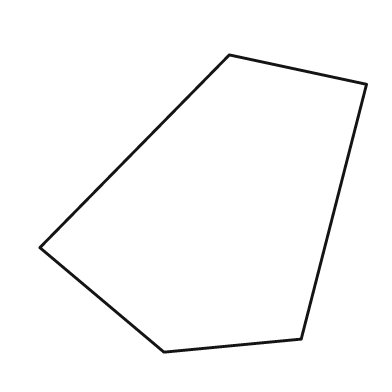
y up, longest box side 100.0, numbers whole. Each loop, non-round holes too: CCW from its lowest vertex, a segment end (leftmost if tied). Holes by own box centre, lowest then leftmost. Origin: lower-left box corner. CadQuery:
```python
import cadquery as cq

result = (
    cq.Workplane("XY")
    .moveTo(38.0, 0.0)
    .lineTo(80.0, 4.0)
    .lineTo(100.0, 82.0)
    .lineTo(58.0, 91.0)
    .lineTo(0.0, 32.0)
    .close()
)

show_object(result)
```